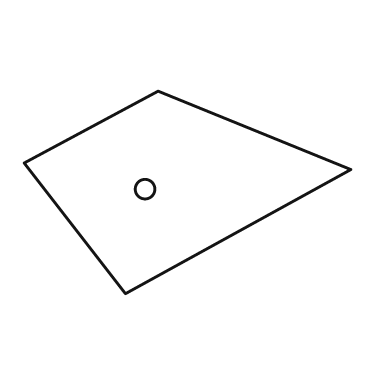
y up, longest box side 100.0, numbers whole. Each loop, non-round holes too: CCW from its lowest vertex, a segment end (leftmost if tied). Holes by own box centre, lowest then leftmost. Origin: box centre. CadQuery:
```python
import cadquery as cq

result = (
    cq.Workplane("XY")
    .moveTo(-19.0, -31.0)
    .lineTo(50.0, 7.0)
    .lineTo(-9.0, 31.0)
    .lineTo(-50.0, 9.0)
    .close()
    .moveTo(-13.0, 1.0)
    .circle(3.0)
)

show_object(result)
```